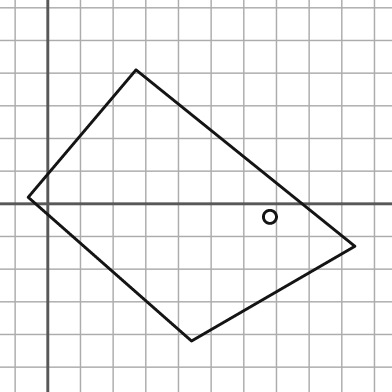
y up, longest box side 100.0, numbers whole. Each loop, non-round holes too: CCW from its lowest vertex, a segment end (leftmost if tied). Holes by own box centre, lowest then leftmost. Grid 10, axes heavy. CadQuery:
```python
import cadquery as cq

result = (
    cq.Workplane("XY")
    .moveTo(44.0, -42.0)
    .lineTo(94.0, -13.0)
    .lineTo(27.0, 41.0)
    .lineTo(-6.0, 2.0)
    .close()
    .moveTo(68.0, -4.0)
    .circle(2.0)
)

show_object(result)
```